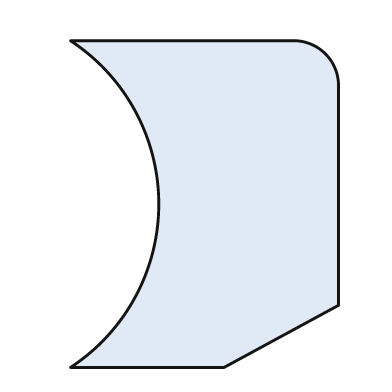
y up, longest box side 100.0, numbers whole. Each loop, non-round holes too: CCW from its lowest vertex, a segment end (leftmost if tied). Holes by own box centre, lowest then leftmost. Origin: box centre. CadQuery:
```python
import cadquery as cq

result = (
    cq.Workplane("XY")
    .moveTo(-41.0, -50.0)
    .lineTo(6.0, -50.0)
    .lineTo(41.0, -31.0)
    .lineTo(41.0, 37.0)
    .threePointArc((37.0, 46.0), (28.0, 50.0))
    .lineTo(-41.0, 50.0)
    .threePointArc((-14.0, 0.0), (-41.0, -50.0))
    .close()
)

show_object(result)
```